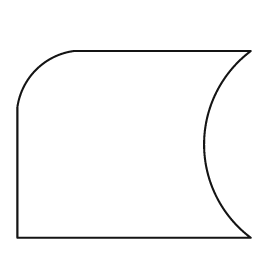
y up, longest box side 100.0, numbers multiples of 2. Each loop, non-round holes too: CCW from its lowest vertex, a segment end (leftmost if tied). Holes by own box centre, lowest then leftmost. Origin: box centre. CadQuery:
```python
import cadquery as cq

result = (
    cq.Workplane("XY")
    .moveTo(-50.0, -40.0)
    .lineTo(50.0, -40.0)
    .threePointArc((30.0, 0.0), (50.0, 40.0))
    .lineTo(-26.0, 40.0)
    .threePointArc((-42.0, 32.0), (-50.0, 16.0))
    .close()
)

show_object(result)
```